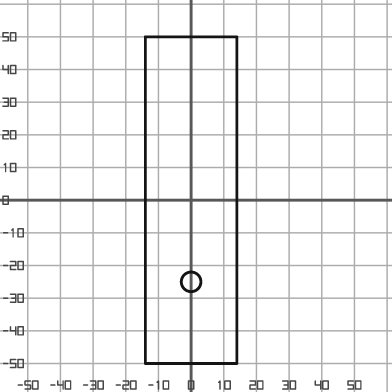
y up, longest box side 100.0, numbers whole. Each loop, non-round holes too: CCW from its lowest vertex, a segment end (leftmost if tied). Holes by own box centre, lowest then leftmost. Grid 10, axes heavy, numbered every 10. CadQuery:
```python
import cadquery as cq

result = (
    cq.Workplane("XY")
    .moveTo(-14.0, -50.0)
    .lineTo(14.0, -50.0)
    .lineTo(14.0, 50.0)
    .lineTo(-14.0, 50.0)
    .close()
    .moveTo(0.0, -25.0)
    .circle(3.0)
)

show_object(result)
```